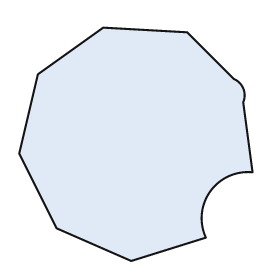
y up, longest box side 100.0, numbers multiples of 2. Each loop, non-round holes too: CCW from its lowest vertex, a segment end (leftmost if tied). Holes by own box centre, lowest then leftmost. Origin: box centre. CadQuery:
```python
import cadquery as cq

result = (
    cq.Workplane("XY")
    .moveTo(-2.0, -50.0)
    .lineTo(30.0, -40.0)
    .threePointArc((32.0, -20.0), (50.0, -12.0))
    .lineTo(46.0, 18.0)
    .threePointArc((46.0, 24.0), (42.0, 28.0))
    .lineTo(22.0, 48.0)
    .lineTo(-14.0, 50.0)
    .lineTo(-42.0, 30.0)
    .lineTo(-50.0, -4.0)
    .lineTo(-34.0, -36.0)
    .close()
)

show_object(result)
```